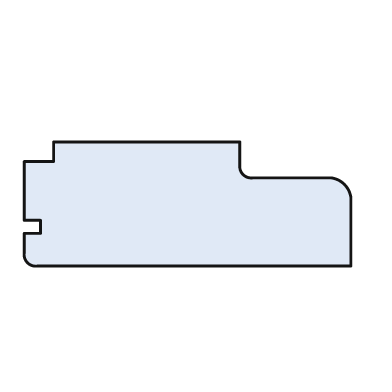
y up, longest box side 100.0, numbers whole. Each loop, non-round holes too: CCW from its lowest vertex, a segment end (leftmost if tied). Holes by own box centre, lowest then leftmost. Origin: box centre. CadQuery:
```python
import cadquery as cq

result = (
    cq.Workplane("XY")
    .moveTo(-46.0, -19.0)
    .lineTo(50.0, -19.0)
    .lineTo(50.0, 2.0)
    .threePointArc((48.0, 6.0), (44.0, 8.0))
    .lineTo(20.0, 8.0)
    .threePointArc((17.0, 9.0), (16.0, 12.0))
    .lineTo(16.0, 19.0)
    .lineTo(-41.0, 19.0)
    .lineTo(-41.0, 13.0)
    .lineTo(-50.0, 13.0)
    .lineTo(-50.0, -5.0)
    .lineTo(-45.0, -5.0)
    .lineTo(-45.0, -9.0)
    .lineTo(-50.0, -9.0)
    .lineTo(-50.0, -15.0)
    .threePointArc((-49.0, -18.0), (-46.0, -19.0))
    .close()
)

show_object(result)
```